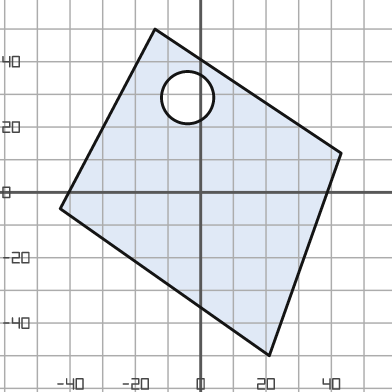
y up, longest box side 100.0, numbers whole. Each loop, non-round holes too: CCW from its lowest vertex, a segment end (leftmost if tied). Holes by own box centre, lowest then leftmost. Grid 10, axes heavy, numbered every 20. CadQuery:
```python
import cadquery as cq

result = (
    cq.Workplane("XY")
    .moveTo(21.0, -50.0)
    .lineTo(43.0, 12.0)
    .lineTo(-14.0, 50.0)
    .lineTo(-43.0, -5.0)
    .close()
    .moveTo(-4.0, 29.0)
    .circle(8.0)
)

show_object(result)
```